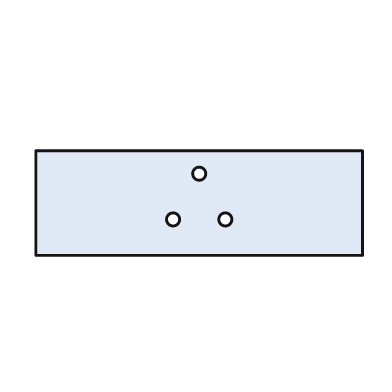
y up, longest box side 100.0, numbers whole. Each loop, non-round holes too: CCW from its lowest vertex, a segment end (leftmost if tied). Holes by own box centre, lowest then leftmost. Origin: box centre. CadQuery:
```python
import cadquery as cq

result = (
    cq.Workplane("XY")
    .moveTo(-50.0, -16.0)
    .lineTo(50.0, -16.0)
    .lineTo(50.0, 16.0)
    .lineTo(-50.0, 16.0)
    .close()
    .moveTo(-8.0, -5.0)
    .circle(2.0)
    .moveTo(8.0, -5.0)
    .circle(2.0)
    .moveTo(0.0, 9.0)
    .circle(2.0)
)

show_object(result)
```